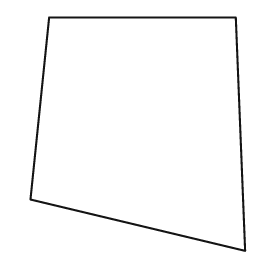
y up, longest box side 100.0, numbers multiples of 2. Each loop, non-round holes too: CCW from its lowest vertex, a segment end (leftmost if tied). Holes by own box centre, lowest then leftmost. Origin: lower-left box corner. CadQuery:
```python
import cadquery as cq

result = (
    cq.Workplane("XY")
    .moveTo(92.0, 0.0)
    .lineTo(88.0, 100.0)
    .lineTo(8.0, 100.0)
    .lineTo(0.0, 22.0)
    .close()
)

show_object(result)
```